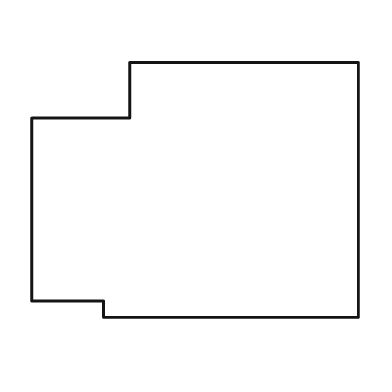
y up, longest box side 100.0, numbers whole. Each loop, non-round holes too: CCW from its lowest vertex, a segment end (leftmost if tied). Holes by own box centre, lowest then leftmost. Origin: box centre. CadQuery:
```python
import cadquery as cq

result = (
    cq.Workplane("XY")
    .moveTo(-28.0, -39.0)
    .lineTo(50.0, -39.0)
    .lineTo(50.0, 39.0)
    .lineTo(-20.0, 39.0)
    .lineTo(-20.0, 22.0)
    .lineTo(-50.0, 22.0)
    .lineTo(-50.0, -34.0)
    .lineTo(-28.0, -34.0)
    .close()
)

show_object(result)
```